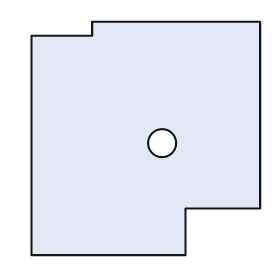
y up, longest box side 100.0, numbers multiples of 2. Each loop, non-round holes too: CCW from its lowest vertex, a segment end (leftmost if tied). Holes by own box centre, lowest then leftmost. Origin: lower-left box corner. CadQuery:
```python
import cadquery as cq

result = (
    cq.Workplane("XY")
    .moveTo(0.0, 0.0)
    .lineTo(66.0, 0.0)
    .lineTo(66.0, 20.0)
    .lineTo(98.0, 20.0)
    .lineTo(98.0, 100.0)
    .lineTo(26.0, 100.0)
    .lineTo(26.0, 94.0)
    .lineTo(0.0, 94.0)
    .close()
    .moveTo(56.0, 48.0)
    .circle(6.0)
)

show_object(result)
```